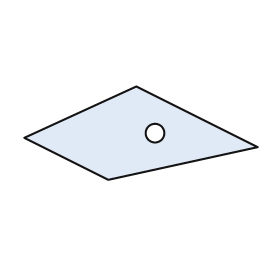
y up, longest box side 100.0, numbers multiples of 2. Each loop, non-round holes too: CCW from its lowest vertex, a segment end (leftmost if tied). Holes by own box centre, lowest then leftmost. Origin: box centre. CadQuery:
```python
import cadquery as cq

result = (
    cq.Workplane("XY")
    .moveTo(-14.0, -20.0)
    .lineTo(50.0, -6.0)
    .lineTo(-2.0, 20.0)
    .lineTo(-50.0, -2.0)
    .close()
    .moveTo(6.0, 0.0)
    .circle(4.0)
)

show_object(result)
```